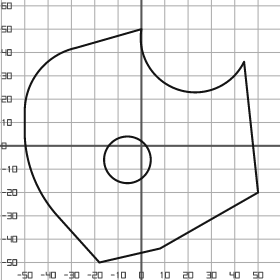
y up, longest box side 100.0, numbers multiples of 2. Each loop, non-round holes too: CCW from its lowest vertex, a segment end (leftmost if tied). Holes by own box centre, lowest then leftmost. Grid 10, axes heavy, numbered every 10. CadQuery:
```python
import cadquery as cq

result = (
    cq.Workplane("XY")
    .moveTo(-18.0, -50.0)
    .lineTo(8.0, -44.0)
    .lineTo(50.0, -20.0)
    .lineTo(44.0, 36.0)
    .threePointArc((16.0, 24.0), (0.0, 50.0))
    .lineTo(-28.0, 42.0)
    .threePointArc((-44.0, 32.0), (-50.0, 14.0))
    .lineTo(-50.0, 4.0)
    .threePointArc((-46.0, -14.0), (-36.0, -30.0))
    .close()
    .moveTo(-6.0, -6.0)
    .circle(10.0)
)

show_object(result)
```